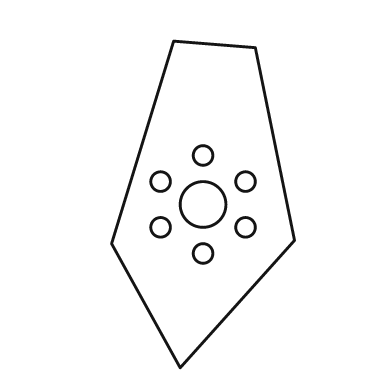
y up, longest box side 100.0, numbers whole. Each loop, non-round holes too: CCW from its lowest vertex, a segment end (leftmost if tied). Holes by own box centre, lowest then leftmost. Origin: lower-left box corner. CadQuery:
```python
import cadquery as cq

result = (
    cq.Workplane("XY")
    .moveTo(21.0, 0.0)
    .lineTo(56.0, 39.0)
    .lineTo(44.0, 98.0)
    .lineTo(19.0, 100.0)
    .lineTo(0.0, 38.0)
    .close()
    .moveTo(28.0, 35.0)
    .circle(3.0)
    .moveTo(15.0, 43.0)
    .circle(3.0)
    .moveTo(41.0, 43.0)
    .circle(3.0)
    .moveTo(28.0, 50.0)
    .circle(7.0)
    .moveTo(15.0, 57.0)
    .circle(3.0)
    .moveTo(41.0, 57.0)
    .circle(3.0)
    .moveTo(28.0, 65.0)
    .circle(3.0)
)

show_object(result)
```